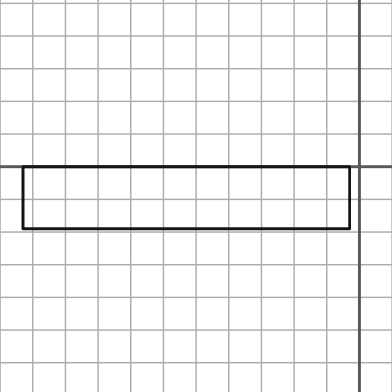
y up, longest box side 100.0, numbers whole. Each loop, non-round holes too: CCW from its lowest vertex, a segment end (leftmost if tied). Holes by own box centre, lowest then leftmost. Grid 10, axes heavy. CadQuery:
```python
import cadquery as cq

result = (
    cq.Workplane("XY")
    .moveTo(-103.0, -19.0)
    .lineTo(-3.0, -19.0)
    .lineTo(-3.0, 0.0)
    .lineTo(-103.0, 0.0)
    .close()
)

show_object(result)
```